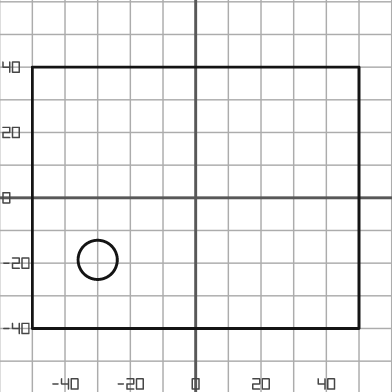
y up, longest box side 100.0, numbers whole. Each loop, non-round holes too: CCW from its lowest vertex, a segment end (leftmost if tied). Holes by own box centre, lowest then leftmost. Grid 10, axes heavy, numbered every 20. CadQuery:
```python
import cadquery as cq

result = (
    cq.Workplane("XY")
    .moveTo(-50.0, -40.0)
    .lineTo(50.0, -40.0)
    .lineTo(50.0, 40.0)
    .lineTo(-50.0, 40.0)
    .close()
    .moveTo(-30.0, -19.0)
    .circle(6.0)
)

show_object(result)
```